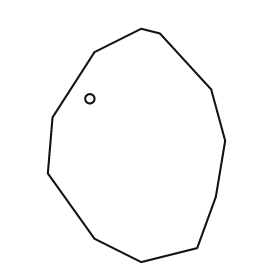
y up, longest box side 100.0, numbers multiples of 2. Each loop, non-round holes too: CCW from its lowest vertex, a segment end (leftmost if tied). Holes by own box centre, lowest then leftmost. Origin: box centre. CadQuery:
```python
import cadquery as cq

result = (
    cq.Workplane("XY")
    .moveTo(2.0, -50.0)
    .lineTo(26.0, -44.0)
    .lineTo(34.0, -22.0)
    .lineTo(38.0, 2.0)
    .lineTo(32.0, 24.0)
    .lineTo(10.0, 48.0)
    .lineTo(2.0, 50.0)
    .lineTo(-18.0, 40.0)
    .lineTo(-36.0, 12.0)
    .lineTo(-38.0, -12.0)
    .lineTo(-18.0, -40.0)
    .close()
    .moveTo(-20.0, 20.0)
    .circle(2.0)
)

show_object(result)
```